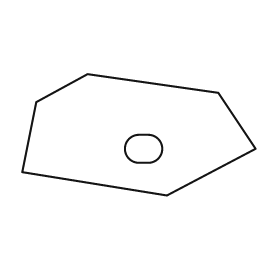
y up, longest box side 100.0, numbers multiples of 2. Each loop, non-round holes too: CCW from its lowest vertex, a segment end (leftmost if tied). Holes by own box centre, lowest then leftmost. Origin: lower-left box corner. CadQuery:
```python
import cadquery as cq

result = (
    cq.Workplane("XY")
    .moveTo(62.0, 0.0)
    .lineTo(100.0, 20.0)
    .lineTo(84.0, 44.0)
    .lineTo(28.0, 52.0)
    .lineTo(6.0, 40.0)
    .lineTo(0.0, 10.0)
    .close()
    .moveTo(50.0, 14.0)
    .lineTo(54.0, 14.0)
    .threePointArc((60.0, 20.0), (54.0, 26.0))
    .lineTo(50.0, 26.0)
    .threePointArc((44.0, 20.0), (50.0, 14.0))
    .close()
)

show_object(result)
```